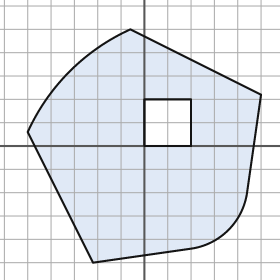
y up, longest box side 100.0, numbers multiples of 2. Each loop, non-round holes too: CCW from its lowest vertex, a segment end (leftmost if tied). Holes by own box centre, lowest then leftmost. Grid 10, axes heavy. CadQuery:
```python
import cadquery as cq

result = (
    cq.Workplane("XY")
    .moveTo(-22.0, -50.0)
    .lineTo(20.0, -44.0)
    .threePointArc((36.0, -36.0), (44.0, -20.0))
    .lineTo(50.0, 22.0)
    .lineTo(-6.0, 50.0)
    .threePointArc((-32.0, 32.0), (-50.0, 6.0))
    .close()
    .moveTo(0.0, 0.0)
    .lineTo(20.0, 0.0)
    .lineTo(20.0, 20.0)
    .lineTo(0.0, 20.0)
    .close()
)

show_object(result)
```